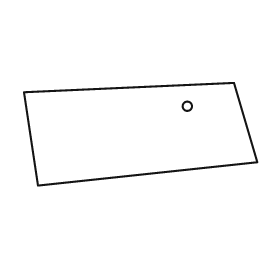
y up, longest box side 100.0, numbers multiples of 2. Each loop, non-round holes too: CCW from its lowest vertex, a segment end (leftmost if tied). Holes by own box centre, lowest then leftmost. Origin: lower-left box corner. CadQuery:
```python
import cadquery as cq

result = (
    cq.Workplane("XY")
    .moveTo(6.0, 0.0)
    .lineTo(100.0, 10.0)
    .lineTo(90.0, 44.0)
    .lineTo(0.0, 40.0)
    .close()
    .moveTo(70.0, 34.0)
    .circle(2.0)
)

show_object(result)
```